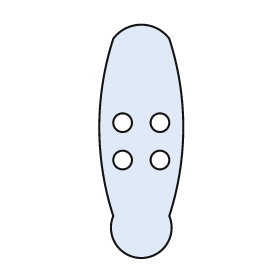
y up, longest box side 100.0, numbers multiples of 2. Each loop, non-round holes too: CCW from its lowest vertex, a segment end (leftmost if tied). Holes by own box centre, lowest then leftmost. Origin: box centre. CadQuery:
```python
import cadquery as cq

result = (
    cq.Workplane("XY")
    .moveTo(-12.0, -32.0)
    .threePointArc((0.0, -50.0), (12.0, -32.0))
    .threePointArc((18.0, 6.0), (12.0, 44.0))
    .threePointArc((0.0, 50.0), (-12.0, 44.0))
    .threePointArc((-18.0, 6.0), (-12.0, -32.0))
    .close()
    .moveTo(-8.0, -8.0)
    .circle(4.0)
    .moveTo(8.0, -8.0)
    .circle(4.0)
    .moveTo(-8.0, 8.0)
    .circle(4.0)
    .moveTo(8.0, 8.0)
    .circle(4.0)
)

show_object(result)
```